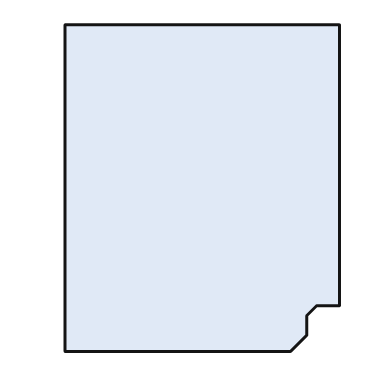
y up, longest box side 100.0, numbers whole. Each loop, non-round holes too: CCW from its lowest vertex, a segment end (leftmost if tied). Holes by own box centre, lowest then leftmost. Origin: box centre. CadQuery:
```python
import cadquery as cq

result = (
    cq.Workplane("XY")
    .moveTo(-42.0, -50.0)
    .lineTo(27.0, -50.0)
    .lineTo(32.0, -45.0)
    .lineTo(32.0, -39.0)
    .lineTo(35.0, -36.0)
    .lineTo(42.0, -36.0)
    .lineTo(42.0, 50.0)
    .lineTo(-42.0, 50.0)
    .close()
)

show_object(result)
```